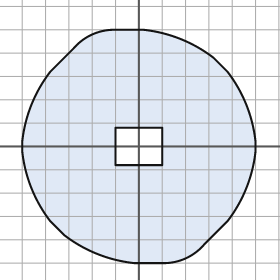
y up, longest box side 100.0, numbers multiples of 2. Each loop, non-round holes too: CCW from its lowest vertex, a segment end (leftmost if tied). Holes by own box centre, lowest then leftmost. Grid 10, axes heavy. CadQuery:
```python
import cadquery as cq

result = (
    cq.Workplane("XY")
    .moveTo(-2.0, -50.0)
    .lineTo(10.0, -50.0)
    .threePointArc((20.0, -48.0), (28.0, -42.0))
    .lineTo(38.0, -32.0)
    .threePointArc((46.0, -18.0), (50.0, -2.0))
    .lineTo(50.0, 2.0)
    .threePointArc((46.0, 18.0), (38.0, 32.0))
    .lineTo(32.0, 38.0)
    .threePointArc((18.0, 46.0), (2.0, 50.0))
    .lineTo(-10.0, 50.0)
    .threePointArc((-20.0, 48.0), (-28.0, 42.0))
    .lineTo(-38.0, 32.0)
    .threePointArc((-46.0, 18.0), (-50.0, 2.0))
    .lineTo(-50.0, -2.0)
    .threePointArc((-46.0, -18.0), (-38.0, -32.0))
    .lineTo(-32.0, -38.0)
    .threePointArc((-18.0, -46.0), (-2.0, -50.0))
    .close()
    .moveTo(-10.0, -8.0)
    .lineTo(10.0, -8.0)
    .lineTo(10.0, 8.0)
    .lineTo(-10.0, 8.0)
    .close()
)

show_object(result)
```